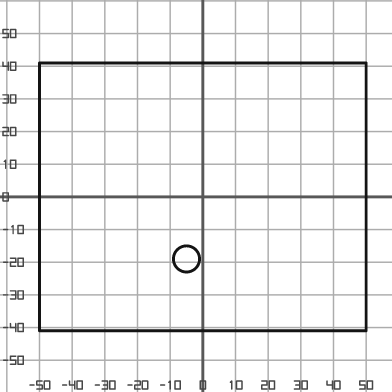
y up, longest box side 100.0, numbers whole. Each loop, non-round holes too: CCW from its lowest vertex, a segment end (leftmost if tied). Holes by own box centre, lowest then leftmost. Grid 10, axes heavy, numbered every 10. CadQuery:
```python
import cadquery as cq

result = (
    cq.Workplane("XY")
    .moveTo(-50.0, -41.0)
    .lineTo(50.0, -41.0)
    .lineTo(50.0, 41.0)
    .lineTo(-50.0, 41.0)
    .close()
    .moveTo(-5.0, -19.0)
    .circle(4.0)
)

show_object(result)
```